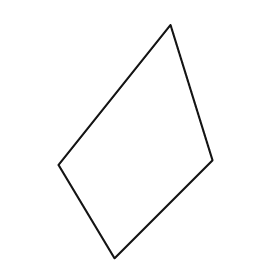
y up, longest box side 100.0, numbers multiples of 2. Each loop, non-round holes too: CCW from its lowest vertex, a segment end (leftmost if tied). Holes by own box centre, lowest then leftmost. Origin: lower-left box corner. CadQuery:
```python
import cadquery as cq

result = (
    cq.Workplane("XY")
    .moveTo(24.0, 0.0)
    .lineTo(66.0, 42.0)
    .lineTo(48.0, 100.0)
    .lineTo(0.0, 40.0)
    .close()
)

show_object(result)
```